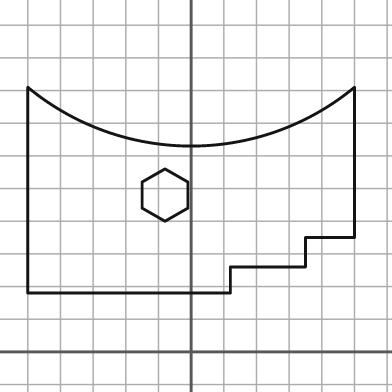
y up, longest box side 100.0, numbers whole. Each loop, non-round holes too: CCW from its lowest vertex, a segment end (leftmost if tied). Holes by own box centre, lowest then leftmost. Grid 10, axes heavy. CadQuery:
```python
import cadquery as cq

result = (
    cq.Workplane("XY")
    .moveTo(-50.0, 18.0)
    .lineTo(12.0, 18.0)
    .lineTo(12.0, 26.0)
    .lineTo(35.0, 26.0)
    .lineTo(35.0, 35.0)
    .lineTo(50.0, 35.0)
    .lineTo(50.0, 81.0)
    .threePointArc((0.0, 63.0), (-50.0, 81.0))
    .close()
    .moveTo(-8.0, 40.0)
    .lineTo(-1.0, 44.0)
    .lineTo(-1.0, 52.0)
    .lineTo(-8.0, 56.0)
    .lineTo(-15.0, 52.0)
    .lineTo(-15.0, 44.0)
    .close()
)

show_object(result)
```